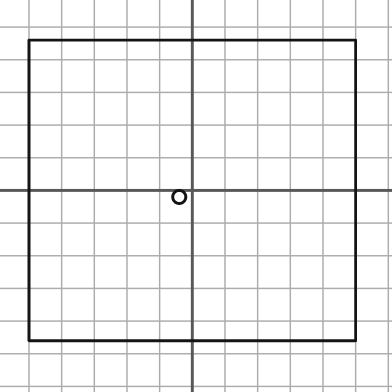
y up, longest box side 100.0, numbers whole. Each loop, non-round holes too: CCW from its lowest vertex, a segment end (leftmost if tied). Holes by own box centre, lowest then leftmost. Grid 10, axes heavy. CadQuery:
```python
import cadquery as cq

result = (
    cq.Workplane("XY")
    .moveTo(-50.0, -46.0)
    .lineTo(50.0, -46.0)
    .lineTo(50.0, 46.0)
    .lineTo(-50.0, 46.0)
    .close()
    .moveTo(-4.0, -2.0)
    .circle(2.0)
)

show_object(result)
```